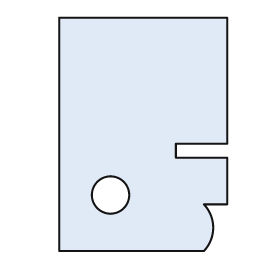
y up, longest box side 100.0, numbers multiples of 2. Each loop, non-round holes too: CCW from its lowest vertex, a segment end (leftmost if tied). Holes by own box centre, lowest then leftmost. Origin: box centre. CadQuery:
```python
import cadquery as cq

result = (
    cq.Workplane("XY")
    .moveTo(-36.0, -50.0)
    .lineTo(26.0, -50.0)
    .threePointArc((30.0, -40.0), (26.0, -30.0))
    .lineTo(36.0, -30.0)
    .lineTo(36.0, -10.0)
    .lineTo(14.0, -10.0)
    .lineTo(14.0, -4.0)
    .lineTo(36.0, -4.0)
    .lineTo(36.0, 50.0)
    .lineTo(-36.0, 50.0)
    .close()
    .moveTo(-14.0, -26.0)
    .circle(8.0)
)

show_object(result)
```